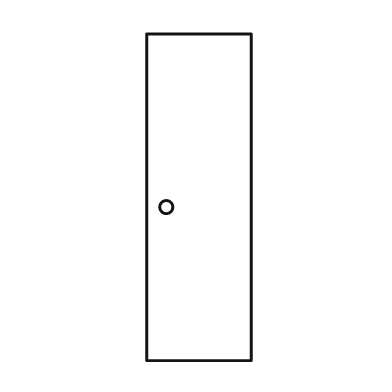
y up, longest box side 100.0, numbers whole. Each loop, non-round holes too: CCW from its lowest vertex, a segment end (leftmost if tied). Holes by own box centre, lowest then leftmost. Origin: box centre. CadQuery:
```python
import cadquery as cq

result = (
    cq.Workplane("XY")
    .moveTo(-16.0, -50.0)
    .lineTo(16.0, -50.0)
    .lineTo(16.0, 50.0)
    .lineTo(-16.0, 50.0)
    .close()
    .moveTo(-10.0, -3.0)
    .circle(2.0)
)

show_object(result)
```